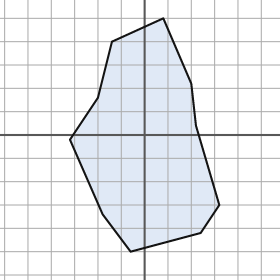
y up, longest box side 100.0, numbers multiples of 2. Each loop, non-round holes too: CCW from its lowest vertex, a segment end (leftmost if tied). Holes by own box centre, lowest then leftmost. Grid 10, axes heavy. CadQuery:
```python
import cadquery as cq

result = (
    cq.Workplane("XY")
    .moveTo(-6.0, -50.0)
    .lineTo(24.0, -42.0)
    .lineTo(32.0, -30.0)
    .lineTo(22.0, 4.0)
    .lineTo(20.0, 22.0)
    .lineTo(8.0, 50.0)
    .lineTo(-14.0, 40.0)
    .lineTo(-20.0, 16.0)
    .lineTo(-32.0, -2.0)
    .lineTo(-18.0, -34.0)
    .close()
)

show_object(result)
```